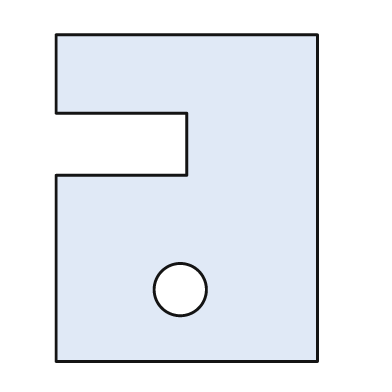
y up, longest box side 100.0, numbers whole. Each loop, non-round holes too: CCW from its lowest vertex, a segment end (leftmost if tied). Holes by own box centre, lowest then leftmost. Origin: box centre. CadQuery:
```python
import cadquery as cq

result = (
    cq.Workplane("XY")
    .moveTo(-40.0, -50.0)
    .lineTo(40.0, -50.0)
    .lineTo(40.0, 50.0)
    .lineTo(-40.0, 50.0)
    .lineTo(-40.0, 26.0)
    .lineTo(0.0, 26.0)
    .lineTo(0.0, 7.0)
    .lineTo(-40.0, 7.0)
    .close()
    .moveTo(-2.0, -28.0)
    .circle(8.0)
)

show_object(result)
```